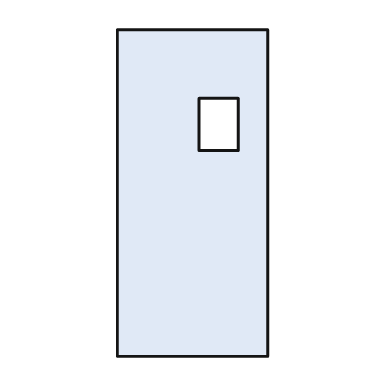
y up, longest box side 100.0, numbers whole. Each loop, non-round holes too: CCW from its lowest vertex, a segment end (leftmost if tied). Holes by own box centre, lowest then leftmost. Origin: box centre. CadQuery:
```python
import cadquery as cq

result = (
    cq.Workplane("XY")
    .moveTo(-23.0, -50.0)
    .lineTo(23.0, -50.0)
    .lineTo(23.0, 50.0)
    .lineTo(-23.0, 50.0)
    .close()
    .moveTo(2.0, 13.0)
    .lineTo(14.0, 13.0)
    .lineTo(14.0, 29.0)
    .lineTo(2.0, 29.0)
    .close()
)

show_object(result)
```